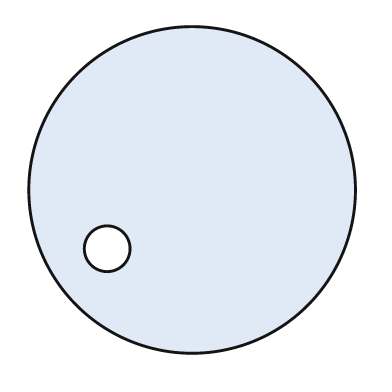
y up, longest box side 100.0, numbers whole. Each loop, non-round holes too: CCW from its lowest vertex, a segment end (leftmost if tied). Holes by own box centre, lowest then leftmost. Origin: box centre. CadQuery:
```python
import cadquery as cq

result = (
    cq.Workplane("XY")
    .moveTo(0.0, 0.0)
    .circle(50.0)
    .moveTo(-26.0, -18.0)
    .circle(7.0)
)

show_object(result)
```